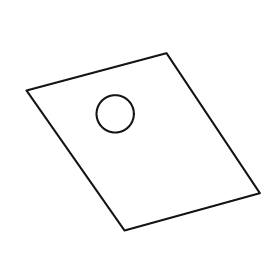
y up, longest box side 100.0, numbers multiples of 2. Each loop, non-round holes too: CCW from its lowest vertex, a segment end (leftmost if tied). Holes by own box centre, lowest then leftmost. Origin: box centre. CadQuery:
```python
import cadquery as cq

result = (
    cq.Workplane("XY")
    .moveTo(-8.0, -38.0)
    .lineTo(50.0, -22.0)
    .lineTo(10.0, 38.0)
    .lineTo(-50.0, 22.0)
    .close()
    .moveTo(-12.0, 12.0)
    .circle(8.0)
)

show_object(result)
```